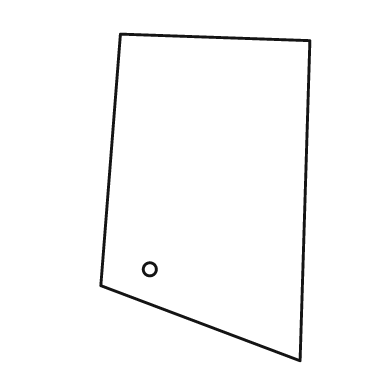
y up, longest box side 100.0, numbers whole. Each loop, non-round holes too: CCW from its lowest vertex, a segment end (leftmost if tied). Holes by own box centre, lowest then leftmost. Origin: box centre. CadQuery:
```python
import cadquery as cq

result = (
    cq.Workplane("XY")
    .moveTo(29.0, -50.0)
    .lineTo(32.0, 48.0)
    .lineTo(-26.0, 50.0)
    .lineTo(-32.0, -27.0)
    .close()
    .moveTo(-17.0, -22.0)
    .circle(2.0)
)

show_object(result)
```